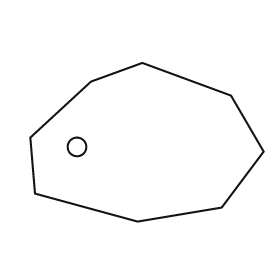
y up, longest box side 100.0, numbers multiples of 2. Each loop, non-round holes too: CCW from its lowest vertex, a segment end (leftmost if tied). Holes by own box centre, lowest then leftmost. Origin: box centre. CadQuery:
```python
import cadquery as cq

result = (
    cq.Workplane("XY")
    .moveTo(-4.0, -34.0)
    .lineTo(32.0, -28.0)
    .lineTo(50.0, -4.0)
    .lineTo(36.0, 20.0)
    .lineTo(-2.0, 34.0)
    .lineTo(-24.0, 26.0)
    .lineTo(-50.0, 2.0)
    .lineTo(-48.0, -22.0)
    .close()
    .moveTo(-30.0, -2.0)
    .circle(4.0)
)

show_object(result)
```